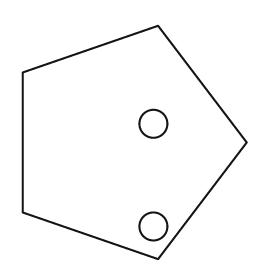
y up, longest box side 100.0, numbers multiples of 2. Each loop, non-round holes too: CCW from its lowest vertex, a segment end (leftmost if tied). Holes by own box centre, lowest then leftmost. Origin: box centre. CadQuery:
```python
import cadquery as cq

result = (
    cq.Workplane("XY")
    .moveTo(10.0, -50.0)
    .lineTo(48.0, 0.0)
    .lineTo(10.0, 50.0)
    .lineTo(-48.0, 30.0)
    .lineTo(-48.0, -30.0)
    .close()
    .moveTo(8.0, -36.0)
    .circle(6.0)
    .moveTo(8.0, 8.0)
    .circle(6.0)
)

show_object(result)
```